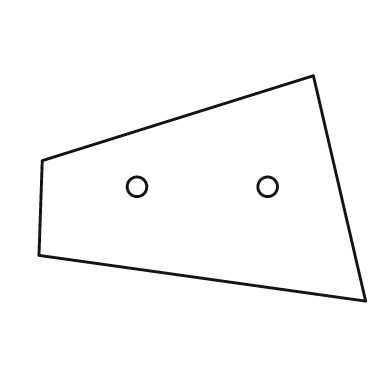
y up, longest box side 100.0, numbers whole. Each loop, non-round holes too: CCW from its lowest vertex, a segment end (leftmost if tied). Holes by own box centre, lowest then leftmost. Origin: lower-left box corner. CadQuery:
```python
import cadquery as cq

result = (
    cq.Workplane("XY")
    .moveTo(100.0, 0.0)
    .lineTo(84.0, 69.0)
    .lineTo(1.0, 43.0)
    .lineTo(0.0, 14.0)
    .close()
    .moveTo(30.0, 35.0)
    .circle(3.0)
    .moveTo(70.0, 35.0)
    .circle(3.0)
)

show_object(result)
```